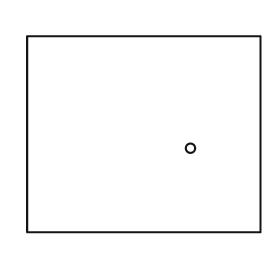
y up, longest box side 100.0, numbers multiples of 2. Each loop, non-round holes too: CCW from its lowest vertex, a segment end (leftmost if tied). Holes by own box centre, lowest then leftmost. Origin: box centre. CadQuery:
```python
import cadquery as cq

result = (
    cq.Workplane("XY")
    .moveTo(-50.0, -42.0)
    .lineTo(50.0, -42.0)
    .lineTo(50.0, 42.0)
    .lineTo(-50.0, 42.0)
    .close()
    .moveTo(20.0, -6.0)
    .circle(2.0)
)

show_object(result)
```